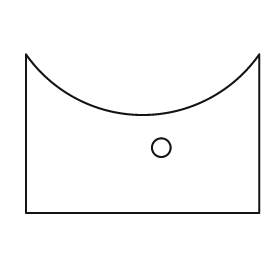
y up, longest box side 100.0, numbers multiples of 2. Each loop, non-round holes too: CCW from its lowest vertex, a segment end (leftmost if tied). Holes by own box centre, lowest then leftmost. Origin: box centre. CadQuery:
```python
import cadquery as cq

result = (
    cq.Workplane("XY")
    .moveTo(-50.0, -34.0)
    .lineTo(50.0, -34.0)
    .lineTo(50.0, 34.0)
    .threePointArc((0.0, 8.0), (-50.0, 34.0))
    .close()
    .moveTo(8.0, -6.0)
    .circle(4.0)
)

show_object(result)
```